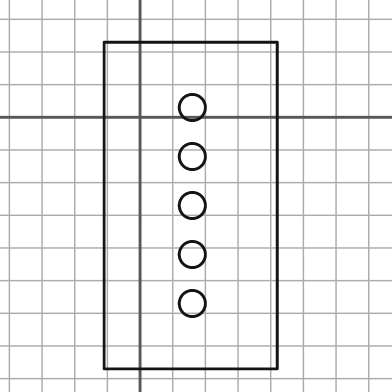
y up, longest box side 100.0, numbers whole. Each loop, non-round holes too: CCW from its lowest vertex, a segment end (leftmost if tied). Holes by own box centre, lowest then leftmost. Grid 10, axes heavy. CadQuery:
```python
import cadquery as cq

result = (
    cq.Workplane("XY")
    .moveTo(-11.0, -77.0)
    .lineTo(42.0, -77.0)
    .lineTo(42.0, 23.0)
    .lineTo(-11.0, 23.0)
    .close()
    .moveTo(16.0, -57.0)
    .circle(4.0)
    .moveTo(16.0, -42.0)
    .circle(4.0)
    .moveTo(16.0, -27.0)
    .circle(4.0)
    .moveTo(16.0, -12.0)
    .circle(4.0)
    .moveTo(16.0, 3.0)
    .circle(4.0)
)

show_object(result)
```